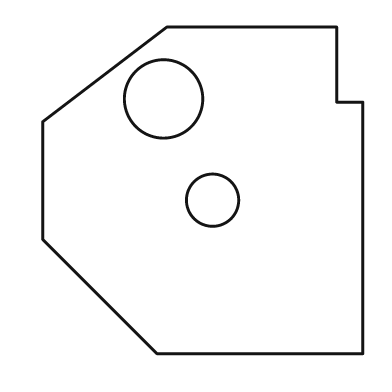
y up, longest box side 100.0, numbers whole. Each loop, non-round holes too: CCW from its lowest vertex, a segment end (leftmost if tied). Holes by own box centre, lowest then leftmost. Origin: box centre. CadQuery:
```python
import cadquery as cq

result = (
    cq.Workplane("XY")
    .moveTo(-14.0, -50.0)
    .lineTo(49.0, -50.0)
    .lineTo(49.0, 27.0)
    .lineTo(41.0, 27.0)
    .lineTo(41.0, 50.0)
    .lineTo(-11.0, 50.0)
    .lineTo(-49.0, 21.0)
    .lineTo(-49.0, -15.0)
    .close()
    .moveTo(3.0, -3.0)
    .circle(8.0)
    .moveTo(-12.0, 28.0)
    .circle(12.0)
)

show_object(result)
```